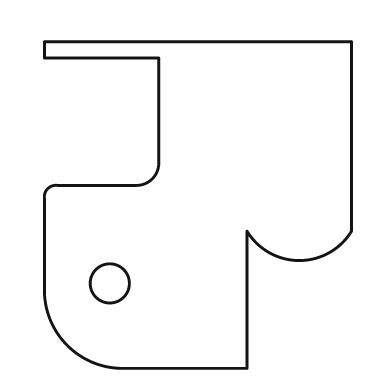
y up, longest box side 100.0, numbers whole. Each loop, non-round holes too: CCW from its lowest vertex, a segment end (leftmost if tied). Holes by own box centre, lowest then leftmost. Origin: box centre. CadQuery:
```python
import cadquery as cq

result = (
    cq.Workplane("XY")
    .moveTo(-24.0, -50.0)
    .lineTo(15.0, -50.0)
    .lineTo(15.0, -8.0)
    .threePointArc((31.0, -17.0), (47.0, -8.0))
    .lineTo(47.0, 50.0)
    .lineTo(-47.0, 50.0)
    .lineTo(-47.0, 45.0)
    .lineTo(-12.0, 45.0)
    .lineTo(-12.0, 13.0)
    .threePointArc((-14.0, 8.0), (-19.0, 6.0))
    .lineTo(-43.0, 6.0)
    .threePointArc((-46.0, 5.0), (-47.0, 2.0))
    .lineTo(-47.0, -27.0)
    .threePointArc((-40.0, -43.0), (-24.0, -50.0))
    .close()
    .moveTo(-27.0, -24.0)
    .circle(6.0)
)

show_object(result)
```